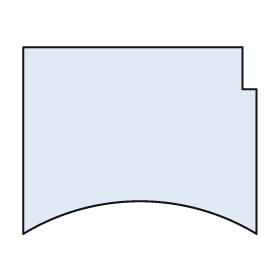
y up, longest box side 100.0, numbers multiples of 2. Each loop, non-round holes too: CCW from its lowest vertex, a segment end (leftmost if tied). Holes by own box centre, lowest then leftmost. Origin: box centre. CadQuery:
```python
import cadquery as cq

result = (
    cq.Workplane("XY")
    .moveTo(-50.0, -40.0)
    .threePointArc((0.0, -26.0), (50.0, -40.0))
    .lineTo(50.0, 22.0)
    .lineTo(44.0, 22.0)
    .lineTo(44.0, 40.0)
    .lineTo(-50.0, 40.0)
    .close()
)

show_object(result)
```